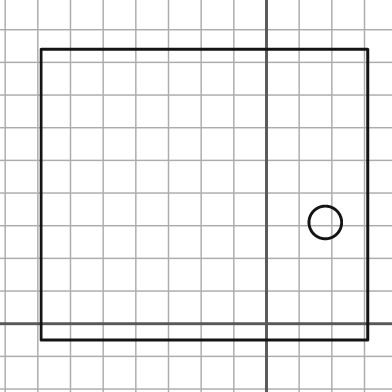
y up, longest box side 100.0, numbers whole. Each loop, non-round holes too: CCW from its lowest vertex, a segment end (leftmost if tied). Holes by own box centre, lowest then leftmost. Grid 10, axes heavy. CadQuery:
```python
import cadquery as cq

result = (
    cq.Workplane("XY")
    .moveTo(-69.0, -5.0)
    .lineTo(31.0, -5.0)
    .lineTo(31.0, 84.0)
    .lineTo(-69.0, 84.0)
    .close()
    .moveTo(18.0, 31.0)
    .circle(5.0)
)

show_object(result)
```